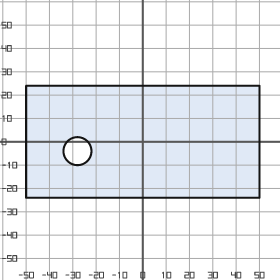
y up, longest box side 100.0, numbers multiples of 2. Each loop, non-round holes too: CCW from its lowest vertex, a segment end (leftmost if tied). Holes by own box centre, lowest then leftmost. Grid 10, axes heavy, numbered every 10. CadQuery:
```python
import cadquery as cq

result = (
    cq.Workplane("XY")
    .moveTo(-50.0, -24.0)
    .lineTo(50.0, -24.0)
    .lineTo(50.0, 24.0)
    .lineTo(-50.0, 24.0)
    .close()
    .moveTo(-28.0, -4.0)
    .circle(6.0)
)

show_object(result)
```